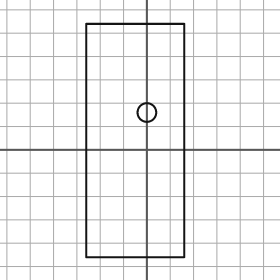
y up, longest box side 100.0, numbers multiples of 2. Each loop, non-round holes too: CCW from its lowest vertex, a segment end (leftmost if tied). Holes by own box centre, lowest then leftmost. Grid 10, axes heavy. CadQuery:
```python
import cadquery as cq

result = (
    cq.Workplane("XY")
    .moveTo(-26.0, -46.0)
    .lineTo(16.0, -46.0)
    .lineTo(16.0, 54.0)
    .lineTo(-26.0, 54.0)
    .close()
    .moveTo(0.0, 16.0)
    .circle(4.0)
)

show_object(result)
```